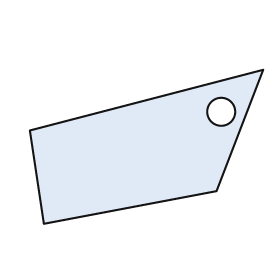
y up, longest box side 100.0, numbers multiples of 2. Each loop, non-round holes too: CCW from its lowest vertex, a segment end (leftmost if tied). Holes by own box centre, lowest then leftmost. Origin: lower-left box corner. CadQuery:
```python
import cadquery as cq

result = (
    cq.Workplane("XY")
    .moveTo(6.0, 0.0)
    .lineTo(80.0, 14.0)
    .lineTo(100.0, 66.0)
    .lineTo(0.0, 40.0)
    .close()
    .moveTo(82.0, 48.0)
    .circle(6.0)
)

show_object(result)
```